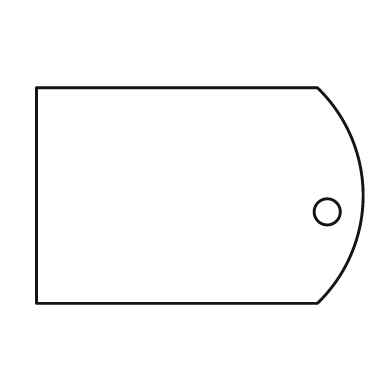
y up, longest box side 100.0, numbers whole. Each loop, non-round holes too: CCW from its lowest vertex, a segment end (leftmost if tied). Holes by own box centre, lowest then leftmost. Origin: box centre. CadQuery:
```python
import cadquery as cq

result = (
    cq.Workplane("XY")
    .moveTo(-50.0, -33.0)
    .lineTo(36.0, -33.0)
    .threePointArc((50.0, 0.0), (36.0, 33.0))
    .lineTo(-50.0, 33.0)
    .close()
    .moveTo(39.0, -5.0)
    .circle(4.0)
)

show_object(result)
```